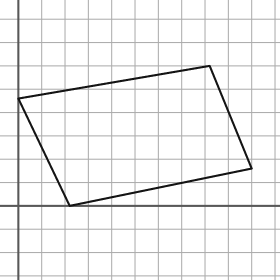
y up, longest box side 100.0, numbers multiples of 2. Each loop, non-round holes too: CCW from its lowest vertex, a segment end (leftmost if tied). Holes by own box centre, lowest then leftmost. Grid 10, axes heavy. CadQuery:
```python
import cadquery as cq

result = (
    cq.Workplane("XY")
    .moveTo(22.0, 0.0)
    .lineTo(100.0, 16.0)
    .lineTo(82.0, 60.0)
    .lineTo(0.0, 46.0)
    .close()
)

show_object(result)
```